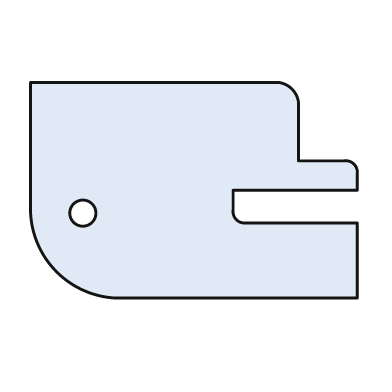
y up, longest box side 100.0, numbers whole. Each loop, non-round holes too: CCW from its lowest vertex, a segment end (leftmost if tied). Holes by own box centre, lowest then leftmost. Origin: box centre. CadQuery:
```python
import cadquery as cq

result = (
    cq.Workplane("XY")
    .moveTo(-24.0, -33.0)
    .lineTo(50.0, -33.0)
    .lineTo(50.0, -10.0)
    .lineTo(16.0, -10.0)
    .threePointArc((13.0, -9.0), (12.0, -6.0))
    .lineTo(12.0, 0.0)
    .lineTo(50.0, 0.0)
    .lineTo(50.0, 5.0)
    .threePointArc((49.0, 8.0), (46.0, 9.0))
    .lineTo(32.0, 9.0)
    .lineTo(32.0, 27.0)
    .threePointArc((30.0, 31.0), (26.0, 33.0))
    .lineTo(-50.0, 33.0)
    .lineTo(-50.0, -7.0)
    .threePointArc((-42.0, -25.0), (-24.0, -33.0))
    .close()
    .moveTo(-34.0, -7.0)
    .circle(4.0)
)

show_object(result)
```